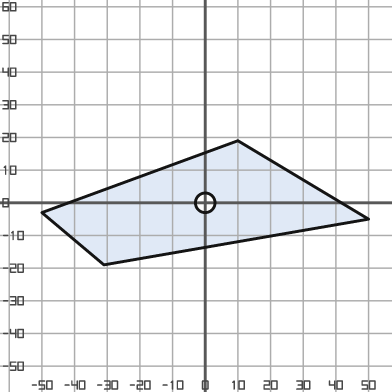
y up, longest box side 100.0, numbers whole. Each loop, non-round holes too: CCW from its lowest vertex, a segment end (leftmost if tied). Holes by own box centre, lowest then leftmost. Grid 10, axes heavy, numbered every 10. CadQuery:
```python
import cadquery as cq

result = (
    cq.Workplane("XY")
    .moveTo(-31.0, -19.0)
    .lineTo(50.0, -5.0)
    .lineTo(10.0, 19.0)
    .lineTo(-50.0, -3.0)
    .close()
    .moveTo(0.0, 0.0)
    .circle(3.0)
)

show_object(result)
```